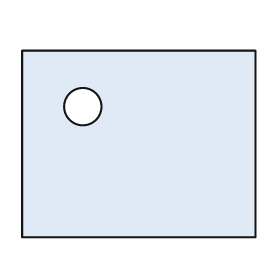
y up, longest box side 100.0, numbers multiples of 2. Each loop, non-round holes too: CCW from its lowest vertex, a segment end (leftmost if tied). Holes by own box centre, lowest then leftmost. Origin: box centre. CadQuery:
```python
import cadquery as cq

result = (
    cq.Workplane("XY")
    .moveTo(-50.0, -40.0)
    .lineTo(50.0, -40.0)
    .lineTo(50.0, 40.0)
    .lineTo(-50.0, 40.0)
    .close()
    .moveTo(-24.0, 16.0)
    .circle(8.0)
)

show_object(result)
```